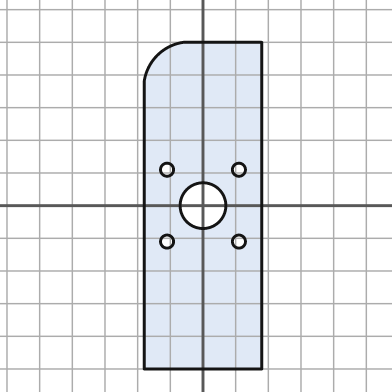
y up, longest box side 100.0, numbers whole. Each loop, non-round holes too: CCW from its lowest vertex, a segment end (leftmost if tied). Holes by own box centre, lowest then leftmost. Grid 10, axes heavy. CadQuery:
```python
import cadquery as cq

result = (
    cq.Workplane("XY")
    .moveTo(-18.0, -50.0)
    .lineTo(18.0, -50.0)
    .lineTo(18.0, 50.0)
    .lineTo(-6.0, 50.0)
    .threePointArc((-14.0, 46.0), (-18.0, 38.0))
    .close()
    .moveTo(-11.0, -11.0)
    .circle(2.0)
    .moveTo(11.0, -11.0)
    .circle(2.0)
    .moveTo(0.0, 0.0)
    .circle(7.0)
    .moveTo(-11.0, 11.0)
    .circle(2.0)
    .moveTo(11.0, 11.0)
    .circle(2.0)
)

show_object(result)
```